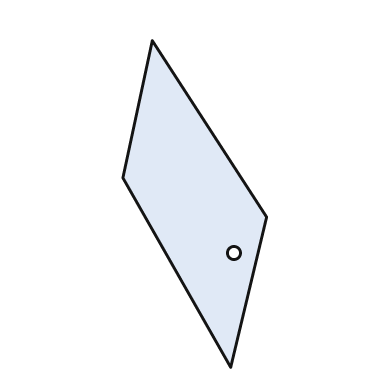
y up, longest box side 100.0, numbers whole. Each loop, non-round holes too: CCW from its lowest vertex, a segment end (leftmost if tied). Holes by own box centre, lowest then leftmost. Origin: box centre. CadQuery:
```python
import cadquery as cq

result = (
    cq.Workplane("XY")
    .moveTo(11.0, -50.0)
    .lineTo(22.0, -4.0)
    .lineTo(-13.0, 50.0)
    .lineTo(-22.0, 8.0)
    .close()
    .moveTo(12.0, -15.0)
    .circle(2.0)
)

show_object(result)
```